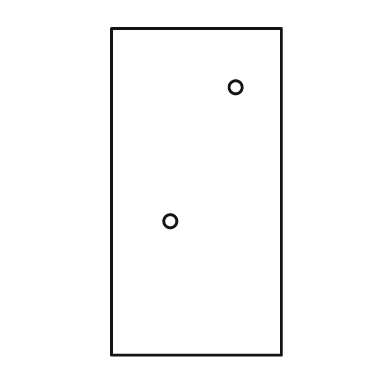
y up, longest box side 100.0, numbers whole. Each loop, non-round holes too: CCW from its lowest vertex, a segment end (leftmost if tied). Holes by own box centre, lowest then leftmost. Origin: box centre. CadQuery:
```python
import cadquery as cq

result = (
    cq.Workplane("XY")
    .moveTo(-26.0, -50.0)
    .lineTo(26.0, -50.0)
    .lineTo(26.0, 50.0)
    .lineTo(-26.0, 50.0)
    .close()
    .moveTo(-8.0, -9.0)
    .circle(2.0)
    .moveTo(12.0, 32.0)
    .circle(2.0)
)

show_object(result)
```